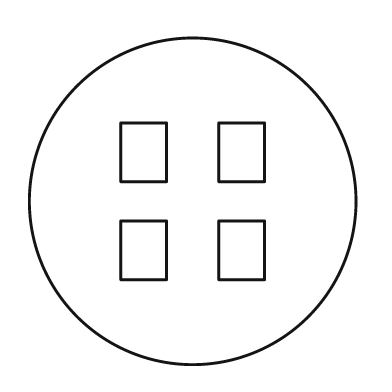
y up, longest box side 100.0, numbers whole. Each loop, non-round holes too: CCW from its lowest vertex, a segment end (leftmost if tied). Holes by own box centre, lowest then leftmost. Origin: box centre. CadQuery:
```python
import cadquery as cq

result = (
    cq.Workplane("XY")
    .moveTo(0.0, 0.0)
    .circle(50.0)
    .moveTo(-22.0, -24.0)
    .lineTo(-8.0, -24.0)
    .lineTo(-8.0, -6.0)
    .lineTo(-22.0, -6.0)
    .close()
    .moveTo(8.0, -24.0)
    .lineTo(22.0, -24.0)
    .lineTo(22.0, -6.0)
    .lineTo(8.0, -6.0)
    .close()
    .moveTo(-22.0, 6.0)
    .lineTo(-8.0, 6.0)
    .lineTo(-8.0, 24.0)
    .lineTo(-22.0, 24.0)
    .close()
    .moveTo(8.0, 6.0)
    .lineTo(22.0, 6.0)
    .lineTo(22.0, 24.0)
    .lineTo(8.0, 24.0)
    .close()
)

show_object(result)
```